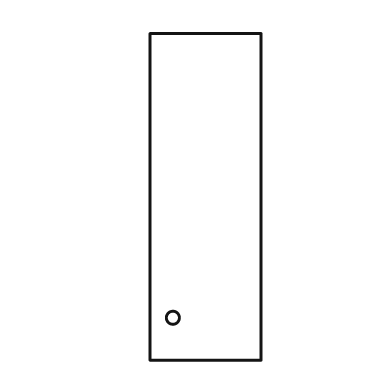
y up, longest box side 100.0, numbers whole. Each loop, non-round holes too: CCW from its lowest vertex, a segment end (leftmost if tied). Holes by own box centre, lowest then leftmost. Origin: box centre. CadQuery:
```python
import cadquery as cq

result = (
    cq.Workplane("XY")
    .moveTo(-17.0, -50.0)
    .lineTo(17.0, -50.0)
    .lineTo(17.0, 50.0)
    .lineTo(-17.0, 50.0)
    .close()
    .moveTo(-10.0, -37.0)
    .circle(2.0)
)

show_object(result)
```